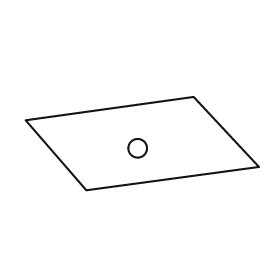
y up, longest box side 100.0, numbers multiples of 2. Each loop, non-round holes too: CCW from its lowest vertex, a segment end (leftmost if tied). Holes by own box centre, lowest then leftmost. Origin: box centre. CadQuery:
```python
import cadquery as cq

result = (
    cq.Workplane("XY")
    .moveTo(-24.0, -20.0)
    .lineTo(50.0, -10.0)
    .lineTo(22.0, 20.0)
    .lineTo(-50.0, 10.0)
    .close()
    .moveTo(-2.0, -2.0)
    .circle(4.0)
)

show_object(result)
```